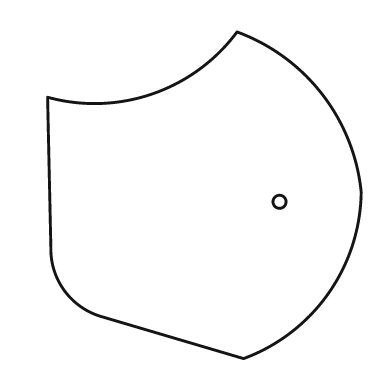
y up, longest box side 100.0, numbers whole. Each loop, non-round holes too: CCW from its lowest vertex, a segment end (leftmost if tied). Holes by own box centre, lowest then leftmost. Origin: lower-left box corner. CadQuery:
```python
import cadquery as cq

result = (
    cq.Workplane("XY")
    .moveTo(60.0, 0.0)
    .threePointArc((86.0, 20.0), (96.0, 51.0))
    .threePointArc((84.0, 81.0), (58.0, 100.0))
    .threePointArc((32.0, 81.0), (0.0, 80.0))
    .lineTo(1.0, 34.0)
    .threePointArc((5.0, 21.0), (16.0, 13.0))
    .close()
    .moveTo(71.0, 48.0)
    .circle(2.0)
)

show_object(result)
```